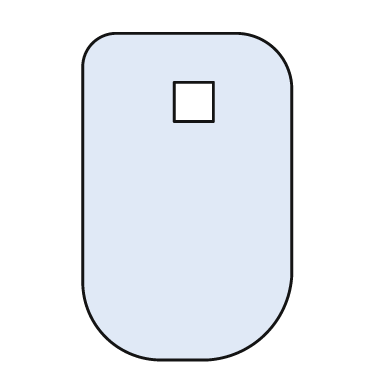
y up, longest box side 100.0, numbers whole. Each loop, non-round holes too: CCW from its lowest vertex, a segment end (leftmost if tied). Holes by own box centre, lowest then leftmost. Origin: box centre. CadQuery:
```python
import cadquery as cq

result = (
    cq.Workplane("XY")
    .moveTo(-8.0, -50.0)
    .lineTo(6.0, -50.0)
    .threePointArc((24.0, -42.0), (32.0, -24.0))
    .lineTo(32.0, 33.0)
    .threePointArc((27.0, 45.0), (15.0, 50.0))
    .lineTo(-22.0, 50.0)
    .threePointArc((-29.0, 47.0), (-32.0, 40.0))
    .lineTo(-32.0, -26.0)
    .threePointArc((-25.0, -43.0), (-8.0, -50.0))
    .close()
    .moveTo(-4.0, 23.0)
    .lineTo(8.0, 23.0)
    .lineTo(8.0, 35.0)
    .lineTo(-4.0, 35.0)
    .close()
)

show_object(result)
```